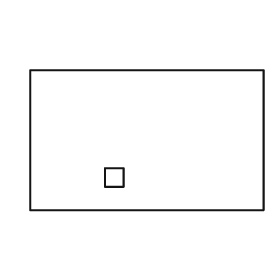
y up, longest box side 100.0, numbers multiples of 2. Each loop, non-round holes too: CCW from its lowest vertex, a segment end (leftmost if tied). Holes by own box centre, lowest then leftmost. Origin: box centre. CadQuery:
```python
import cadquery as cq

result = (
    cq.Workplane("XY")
    .moveTo(-50.0, -30.0)
    .lineTo(50.0, -30.0)
    .lineTo(50.0, 30.0)
    .lineTo(-50.0, 30.0)
    .close()
    .moveTo(-18.0, -20.0)
    .lineTo(-10.0, -20.0)
    .lineTo(-10.0, -12.0)
    .lineTo(-18.0, -12.0)
    .close()
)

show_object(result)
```